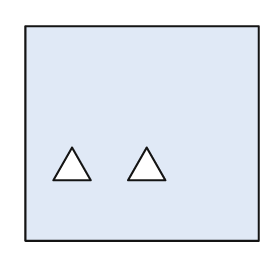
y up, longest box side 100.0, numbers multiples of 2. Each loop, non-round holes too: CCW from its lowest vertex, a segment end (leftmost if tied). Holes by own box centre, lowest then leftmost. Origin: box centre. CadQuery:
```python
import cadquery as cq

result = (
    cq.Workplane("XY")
    .moveTo(-50.0, -46.0)
    .lineTo(50.0, -46.0)
    .lineTo(50.0, 46.0)
    .lineTo(-50.0, 46.0)
    .close()
    .moveTo(-38.0, -20.0)
    .lineTo(-22.0, -20.0)
    .lineTo(-30.0, -6.0)
    .close()
    .moveTo(-6.0, -20.0)
    .lineTo(10.0, -20.0)
    .lineTo(2.0, -6.0)
    .close()
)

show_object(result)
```